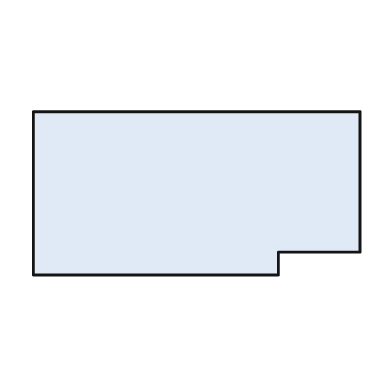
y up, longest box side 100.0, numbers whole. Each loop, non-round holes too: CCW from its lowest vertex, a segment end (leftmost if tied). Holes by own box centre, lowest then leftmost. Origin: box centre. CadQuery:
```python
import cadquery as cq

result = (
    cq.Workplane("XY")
    .moveTo(-50.0, -25.0)
    .lineTo(25.0, -25.0)
    .lineTo(25.0, -18.0)
    .lineTo(50.0, -18.0)
    .lineTo(50.0, 25.0)
    .lineTo(-50.0, 25.0)
    .close()
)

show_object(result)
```